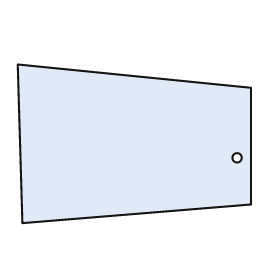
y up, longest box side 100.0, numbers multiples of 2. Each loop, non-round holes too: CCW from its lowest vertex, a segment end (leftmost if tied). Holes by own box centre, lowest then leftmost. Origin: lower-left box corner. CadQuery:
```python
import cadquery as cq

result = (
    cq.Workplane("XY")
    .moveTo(2.0, 0.0)
    .lineTo(100.0, 8.0)
    .lineTo(100.0, 58.0)
    .lineTo(0.0, 68.0)
    .close()
    .moveTo(94.0, 28.0)
    .circle(2.0)
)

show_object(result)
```